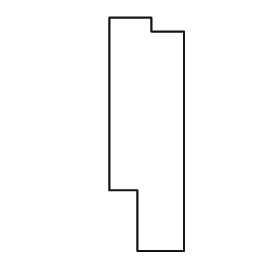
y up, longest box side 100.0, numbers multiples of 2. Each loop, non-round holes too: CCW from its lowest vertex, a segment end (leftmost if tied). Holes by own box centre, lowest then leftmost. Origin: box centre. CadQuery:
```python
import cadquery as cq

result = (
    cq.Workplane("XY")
    .moveTo(-4.0, -50.0)
    .lineTo(16.0, -50.0)
    .lineTo(16.0, 44.0)
    .lineTo(2.0, 44.0)
    .lineTo(2.0, 50.0)
    .lineTo(-16.0, 50.0)
    .lineTo(-16.0, -24.0)
    .lineTo(-4.0, -24.0)
    .close()
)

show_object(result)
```